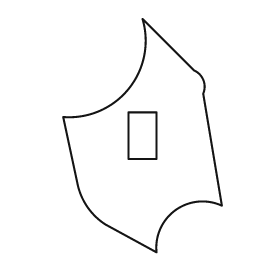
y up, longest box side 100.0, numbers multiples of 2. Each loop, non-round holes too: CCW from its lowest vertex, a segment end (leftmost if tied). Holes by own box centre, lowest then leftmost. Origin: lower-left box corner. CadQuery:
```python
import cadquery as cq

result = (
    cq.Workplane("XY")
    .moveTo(40.0, 0.0)
    .threePointArc((48.0, 18.0), (68.0, 20.0))
    .lineTo(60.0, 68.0)
    .threePointArc((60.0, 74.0), (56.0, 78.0))
    .lineTo(34.0, 100.0)
    .threePointArc((28.0, 70.0), (0.0, 58.0))
    .lineTo(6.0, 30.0)
    .threePointArc((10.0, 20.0), (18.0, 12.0))
    .close()
    .moveTo(28.0, 40.0)
    .lineTo(40.0, 40.0)
    .lineTo(40.0, 60.0)
    .lineTo(28.0, 60.0)
    .close()
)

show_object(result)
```